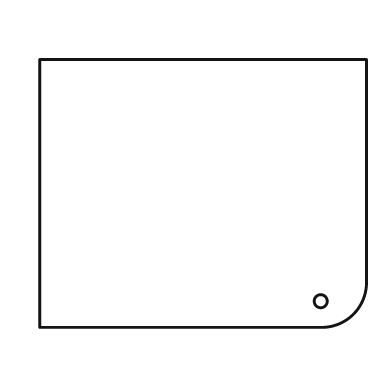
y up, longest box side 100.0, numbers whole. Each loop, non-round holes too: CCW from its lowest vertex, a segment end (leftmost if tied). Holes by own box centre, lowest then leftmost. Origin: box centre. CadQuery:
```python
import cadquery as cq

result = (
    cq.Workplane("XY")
    .moveTo(-50.0, -41.0)
    .lineTo(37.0, -41.0)
    .threePointArc((46.0, -37.0), (50.0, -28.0))
    .lineTo(50.0, 41.0)
    .lineTo(-50.0, 41.0)
    .close()
    .moveTo(36.0, -33.0)
    .circle(2.0)
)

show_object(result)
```